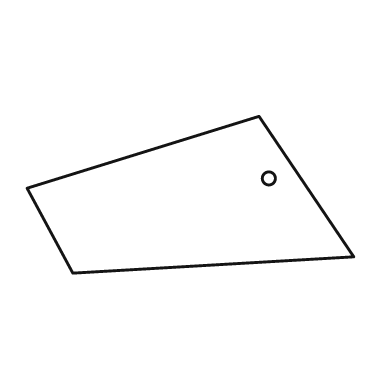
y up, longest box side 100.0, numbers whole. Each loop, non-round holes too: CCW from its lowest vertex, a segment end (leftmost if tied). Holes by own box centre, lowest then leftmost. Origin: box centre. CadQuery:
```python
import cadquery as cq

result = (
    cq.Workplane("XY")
    .moveTo(-36.0, -24.0)
    .lineTo(50.0, -19.0)
    .lineTo(21.0, 24.0)
    .lineTo(-50.0, 2.0)
    .close()
    .moveTo(24.0, 5.0)
    .circle(2.0)
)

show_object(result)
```